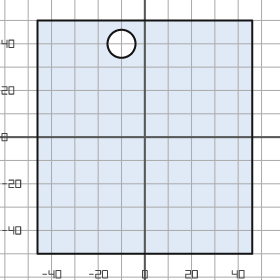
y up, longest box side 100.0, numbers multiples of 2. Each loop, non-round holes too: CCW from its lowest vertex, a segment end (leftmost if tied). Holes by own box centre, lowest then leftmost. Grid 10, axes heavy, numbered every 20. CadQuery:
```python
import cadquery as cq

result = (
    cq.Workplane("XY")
    .moveTo(-46.0, -50.0)
    .lineTo(46.0, -50.0)
    .lineTo(46.0, 50.0)
    .lineTo(-46.0, 50.0)
    .close()
    .moveTo(-10.0, 40.0)
    .circle(6.0)
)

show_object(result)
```